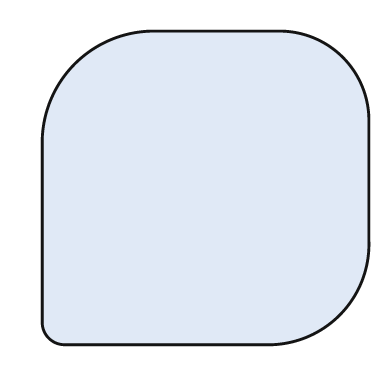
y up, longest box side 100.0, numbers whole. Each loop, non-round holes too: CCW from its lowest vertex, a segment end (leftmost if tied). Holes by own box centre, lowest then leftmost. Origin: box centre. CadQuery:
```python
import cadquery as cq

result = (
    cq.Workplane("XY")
    .moveTo(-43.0, -48.0)
    .lineTo(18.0, -48.0)
    .threePointArc((41.0, -39.0), (50.0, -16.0))
    .lineTo(50.0, 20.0)
    .threePointArc((42.0, 40.0), (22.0, 48.0))
    .lineTo(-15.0, 48.0)
    .threePointArc((-40.0, 38.0), (-50.0, 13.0))
    .lineTo(-50.0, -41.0)
    .threePointArc((-48.0, -46.0), (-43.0, -48.0))
    .close()
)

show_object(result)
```